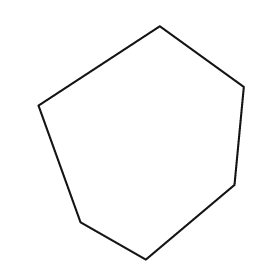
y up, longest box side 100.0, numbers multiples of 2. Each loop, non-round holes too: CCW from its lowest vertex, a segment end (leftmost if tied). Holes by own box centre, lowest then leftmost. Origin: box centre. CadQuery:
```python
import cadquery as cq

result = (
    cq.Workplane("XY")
    .moveTo(2.0, -50.0)
    .lineTo(40.0, -18.0)
    .lineTo(44.0, 24.0)
    .lineTo(8.0, 50.0)
    .lineTo(-44.0, 16.0)
    .lineTo(-26.0, -34.0)
    .close()
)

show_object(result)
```